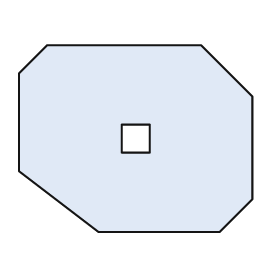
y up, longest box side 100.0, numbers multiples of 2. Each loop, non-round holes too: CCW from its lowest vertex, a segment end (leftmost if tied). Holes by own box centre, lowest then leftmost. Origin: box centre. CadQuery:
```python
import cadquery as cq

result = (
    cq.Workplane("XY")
    .moveTo(-16.0, -40.0)
    .lineTo(36.0, -40.0)
    .lineTo(50.0, -26.0)
    .lineTo(50.0, 18.0)
    .lineTo(28.0, 40.0)
    .lineTo(-38.0, 40.0)
    .lineTo(-50.0, 28.0)
    .lineTo(-50.0, -14.0)
    .close()
    .moveTo(-6.0, -6.0)
    .lineTo(6.0, -6.0)
    .lineTo(6.0, 6.0)
    .lineTo(-6.0, 6.0)
    .close()
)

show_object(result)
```